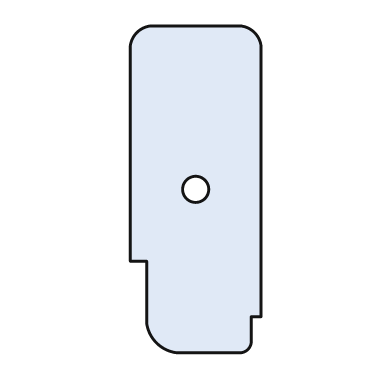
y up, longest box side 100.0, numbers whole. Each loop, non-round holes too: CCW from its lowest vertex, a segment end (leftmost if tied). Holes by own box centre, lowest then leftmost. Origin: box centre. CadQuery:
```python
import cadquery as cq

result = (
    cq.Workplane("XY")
    .moveTo(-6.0, -50.0)
    .lineTo(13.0, -50.0)
    .threePointArc((16.0, -49.0), (17.0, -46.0))
    .lineTo(17.0, -39.0)
    .lineTo(20.0, -39.0)
    .lineTo(20.0, 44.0)
    .threePointArc((18.0, 48.0), (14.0, 50.0))
    .lineTo(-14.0, 50.0)
    .threePointArc((-18.0, 48.0), (-20.0, 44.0))
    .lineTo(-20.0, -22.0)
    .lineTo(-15.0, -22.0)
    .lineTo(-15.0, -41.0)
    .threePointArc((-12.0, -47.0), (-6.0, -50.0))
    .close()
    .moveTo(0.0, 0.0)
    .circle(4.0)
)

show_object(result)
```